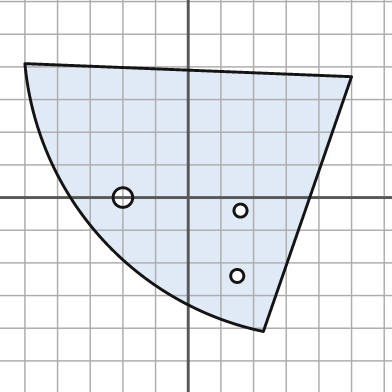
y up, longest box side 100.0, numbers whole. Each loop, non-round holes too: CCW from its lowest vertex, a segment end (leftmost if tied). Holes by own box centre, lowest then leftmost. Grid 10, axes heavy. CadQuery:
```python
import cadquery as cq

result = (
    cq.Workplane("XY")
    .moveTo(23.0, -41.0)
    .lineTo(50.0, 37.0)
    .lineTo(-50.0, 41.0)
    .threePointArc((-27.0, -12.0), (23.0, -41.0))
    .close()
    .moveTo(15.0, -24.0)
    .circle(2.0)
    .moveTo(16.0, -4.0)
    .circle(2.0)
    .moveTo(-20.0, 0.0)
    .circle(3.0)
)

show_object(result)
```